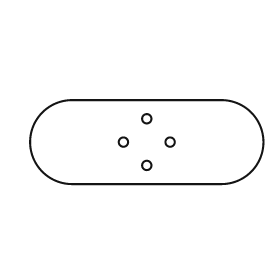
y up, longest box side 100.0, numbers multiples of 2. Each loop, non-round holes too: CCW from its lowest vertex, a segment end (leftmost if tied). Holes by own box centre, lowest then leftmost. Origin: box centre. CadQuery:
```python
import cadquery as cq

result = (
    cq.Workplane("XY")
    .moveTo(-32.0, -18.0)
    .lineTo(32.0, -18.0)
    .threePointArc((50.0, 0.0), (32.0, 18.0))
    .lineTo(-32.0, 18.0)
    .threePointArc((-50.0, 0.0), (-32.0, -18.0))
    .close()
    .moveTo(0.0, -10.0)
    .circle(2.0)
    .moveTo(-10.0, 0.0)
    .circle(2.0)
    .moveTo(10.0, 0.0)
    .circle(2.0)
    .moveTo(0.0, 10.0)
    .circle(2.0)
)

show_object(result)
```